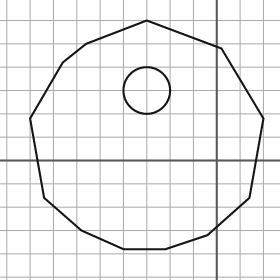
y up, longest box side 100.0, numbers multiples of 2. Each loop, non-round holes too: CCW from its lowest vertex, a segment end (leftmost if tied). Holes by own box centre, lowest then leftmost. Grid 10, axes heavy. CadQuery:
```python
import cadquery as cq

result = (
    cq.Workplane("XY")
    .moveTo(-40.0, -38.0)
    .lineTo(-22.0, -38.0)
    .lineTo(-4.0, -32.0)
    .lineTo(14.0, -16.0)
    .lineTo(20.0, 18.0)
    .lineTo(2.0, 48.0)
    .lineTo(-30.0, 60.0)
    .lineTo(-56.0, 50.0)
    .lineTo(-66.0, 42.0)
    .lineTo(-80.0, 18.0)
    .lineTo(-74.0, -16.0)
    .lineTo(-58.0, -30.0)
    .close()
    .moveTo(-30.0, 30.0)
    .circle(10.0)
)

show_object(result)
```